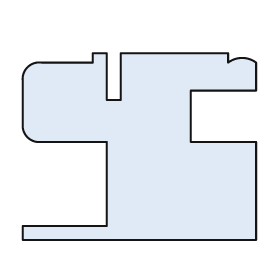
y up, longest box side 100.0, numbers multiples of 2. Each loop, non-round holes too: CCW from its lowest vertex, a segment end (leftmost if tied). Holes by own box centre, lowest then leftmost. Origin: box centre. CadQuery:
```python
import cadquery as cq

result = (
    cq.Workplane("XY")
    .moveTo(-50.0, -40.0)
    .lineTo(50.0, -40.0)
    .lineTo(50.0, 2.0)
    .lineTo(22.0, 2.0)
    .lineTo(22.0, 24.0)
    .lineTo(50.0, 24.0)
    .lineTo(50.0, 36.0)
    .threePointArc((44.0, 38.0), (38.0, 36.0))
    .lineTo(38.0, 40.0)
    .lineTo(-8.0, 40.0)
    .lineTo(-8.0, 20.0)
    .lineTo(-14.0, 20.0)
    .lineTo(-14.0, 40.0)
    .lineTo(-20.0, 40.0)
    .lineTo(-20.0, 36.0)
    .lineTo(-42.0, 36.0)
    .threePointArc((-48.0, 34.0), (-50.0, 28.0))
    .lineTo(-50.0, 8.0)
    .threePointArc((-48.0, 4.0), (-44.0, 2.0))
    .lineTo(-14.0, 2.0)
    .lineTo(-14.0, -34.0)
    .lineTo(-50.0, -34.0)
    .close()
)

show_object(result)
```